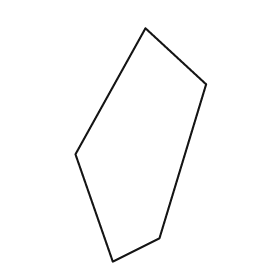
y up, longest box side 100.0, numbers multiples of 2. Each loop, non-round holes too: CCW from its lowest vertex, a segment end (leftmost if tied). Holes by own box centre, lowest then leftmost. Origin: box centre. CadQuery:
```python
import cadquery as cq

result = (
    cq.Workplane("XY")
    .moveTo(-12.0, -50.0)
    .lineTo(8.0, -40.0)
    .lineTo(28.0, 26.0)
    .lineTo(2.0, 50.0)
    .lineTo(-28.0, -4.0)
    .close()
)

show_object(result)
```